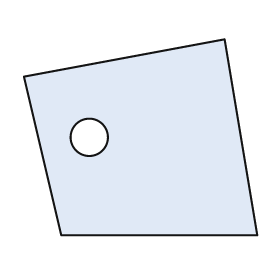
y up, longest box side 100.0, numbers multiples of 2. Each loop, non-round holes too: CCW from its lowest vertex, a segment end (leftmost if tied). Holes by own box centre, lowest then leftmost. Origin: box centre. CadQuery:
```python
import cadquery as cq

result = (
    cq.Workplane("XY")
    .moveTo(-34.0, -42.0)
    .lineTo(50.0, -42.0)
    .lineTo(36.0, 42.0)
    .lineTo(-50.0, 26.0)
    .close()
    .moveTo(-22.0, 0.0)
    .circle(8.0)
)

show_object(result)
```